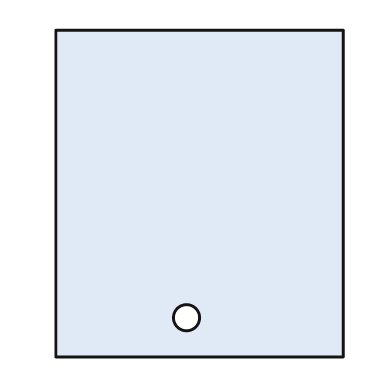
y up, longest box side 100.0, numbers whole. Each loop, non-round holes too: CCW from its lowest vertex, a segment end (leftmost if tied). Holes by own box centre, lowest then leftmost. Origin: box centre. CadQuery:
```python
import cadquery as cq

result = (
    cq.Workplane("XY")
    .moveTo(-44.0, -50.0)
    .lineTo(44.0, -50.0)
    .lineTo(44.0, 50.0)
    .lineTo(-44.0, 50.0)
    .close()
    .moveTo(-4.0, -38.0)
    .circle(4.0)
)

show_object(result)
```